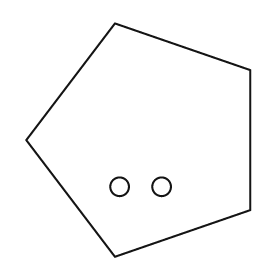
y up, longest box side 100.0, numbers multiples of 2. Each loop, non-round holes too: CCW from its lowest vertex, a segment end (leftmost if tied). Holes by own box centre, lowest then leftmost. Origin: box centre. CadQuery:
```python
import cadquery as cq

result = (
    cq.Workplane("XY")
    .moveTo(-10.0, -50.0)
    .lineTo(48.0, -30.0)
    .lineTo(48.0, 30.0)
    .lineTo(-10.0, 50.0)
    .lineTo(-48.0, 0.0)
    .close()
    .moveTo(-8.0, -20.0)
    .circle(4.0)
    .moveTo(10.0, -20.0)
    .circle(4.0)
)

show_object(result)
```